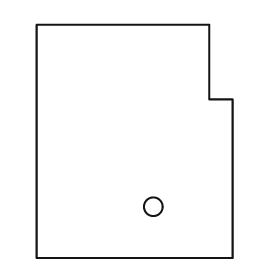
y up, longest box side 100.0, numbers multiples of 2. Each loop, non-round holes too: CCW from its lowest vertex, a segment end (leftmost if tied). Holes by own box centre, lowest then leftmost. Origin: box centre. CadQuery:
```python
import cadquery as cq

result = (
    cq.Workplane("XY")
    .moveTo(-42.0, -50.0)
    .lineTo(42.0, -50.0)
    .lineTo(42.0, 18.0)
    .lineTo(32.0, 18.0)
    .lineTo(32.0, 50.0)
    .lineTo(-42.0, 50.0)
    .close()
    .moveTo(8.0, -28.0)
    .circle(4.0)
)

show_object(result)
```